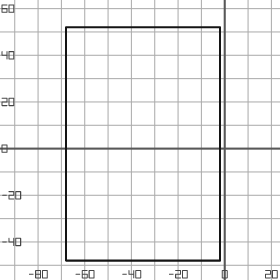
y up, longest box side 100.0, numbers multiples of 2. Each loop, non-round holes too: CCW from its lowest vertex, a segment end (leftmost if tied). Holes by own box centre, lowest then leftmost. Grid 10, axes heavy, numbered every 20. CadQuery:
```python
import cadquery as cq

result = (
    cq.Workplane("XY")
    .moveTo(-68.0, -48.0)
    .lineTo(-2.0, -48.0)
    .lineTo(-2.0, 52.0)
    .lineTo(-68.0, 52.0)
    .close()
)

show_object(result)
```